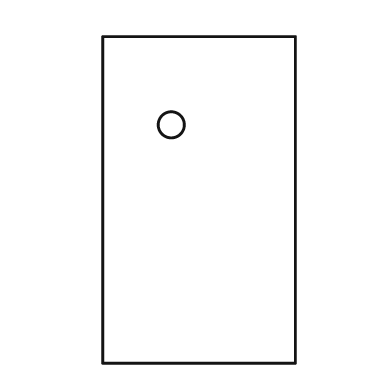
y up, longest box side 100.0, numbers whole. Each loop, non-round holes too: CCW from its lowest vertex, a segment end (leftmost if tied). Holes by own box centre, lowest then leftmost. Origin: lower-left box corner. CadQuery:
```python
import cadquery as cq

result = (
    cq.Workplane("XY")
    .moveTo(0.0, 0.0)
    .lineTo(59.0, 0.0)
    .lineTo(59.0, 100.0)
    .lineTo(0.0, 100.0)
    .close()
    .moveTo(21.0, 73.0)
    .circle(4.0)
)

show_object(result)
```